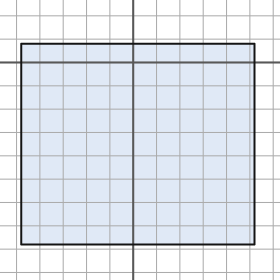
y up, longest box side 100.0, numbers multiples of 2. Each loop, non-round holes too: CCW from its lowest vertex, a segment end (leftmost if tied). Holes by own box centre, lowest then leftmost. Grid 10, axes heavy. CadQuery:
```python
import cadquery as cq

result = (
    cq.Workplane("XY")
    .moveTo(-48.0, -78.0)
    .lineTo(52.0, -78.0)
    .lineTo(52.0, 8.0)
    .lineTo(-48.0, 8.0)
    .close()
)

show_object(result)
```